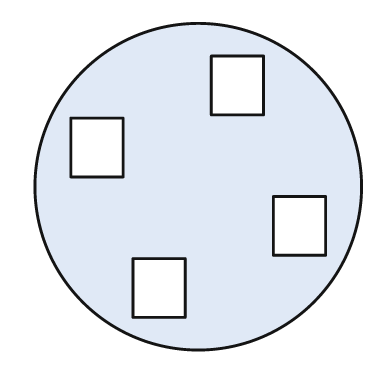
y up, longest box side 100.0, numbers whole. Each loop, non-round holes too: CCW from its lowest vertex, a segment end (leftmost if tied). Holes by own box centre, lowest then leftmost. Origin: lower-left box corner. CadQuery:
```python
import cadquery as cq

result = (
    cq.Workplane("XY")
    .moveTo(50.0, 50.0)
    .circle(50.0)
    .moveTo(30.0, 10.0)
    .lineTo(46.0, 10.0)
    .lineTo(46.0, 28.0)
    .lineTo(30.0, 28.0)
    .close()
    .moveTo(73.0, 29.0)
    .lineTo(89.0, 29.0)
    .lineTo(89.0, 47.0)
    .lineTo(73.0, 47.0)
    .close()
    .moveTo(11.0, 53.0)
    .lineTo(27.0, 53.0)
    .lineTo(27.0, 71.0)
    .lineTo(11.0, 71.0)
    .close()
    .moveTo(54.0, 72.0)
    .lineTo(70.0, 72.0)
    .lineTo(70.0, 90.0)
    .lineTo(54.0, 90.0)
    .close()
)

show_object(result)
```